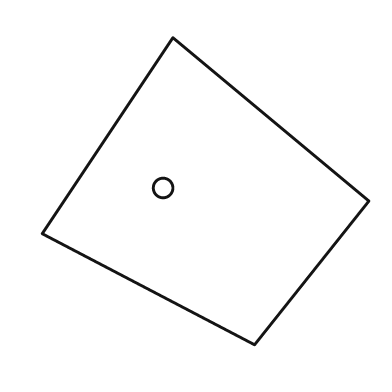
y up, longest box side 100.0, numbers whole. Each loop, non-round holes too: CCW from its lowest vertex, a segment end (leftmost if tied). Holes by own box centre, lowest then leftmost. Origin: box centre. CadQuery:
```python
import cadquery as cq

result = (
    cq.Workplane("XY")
    .moveTo(15.0, -47.0)
    .lineTo(50.0, -3.0)
    .lineTo(-10.0, 47.0)
    .lineTo(-50.0, -13.0)
    .close()
    .moveTo(-13.0, 1.0)
    .circle(3.0)
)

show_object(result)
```